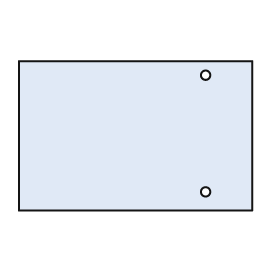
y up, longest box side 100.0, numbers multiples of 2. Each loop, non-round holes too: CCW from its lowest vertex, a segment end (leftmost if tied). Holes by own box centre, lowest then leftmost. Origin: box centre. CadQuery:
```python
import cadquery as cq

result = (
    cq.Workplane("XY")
    .moveTo(-50.0, -32.0)
    .lineTo(50.0, -32.0)
    .lineTo(50.0, 32.0)
    .lineTo(-50.0, 32.0)
    .close()
    .moveTo(30.0, -24.0)
    .circle(2.0)
    .moveTo(30.0, 26.0)
    .circle(2.0)
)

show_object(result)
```